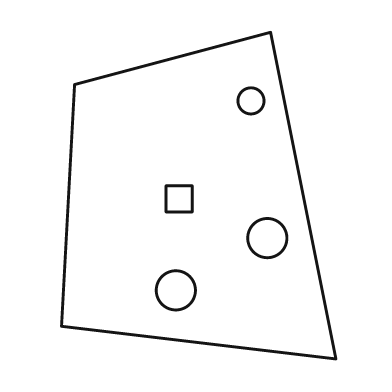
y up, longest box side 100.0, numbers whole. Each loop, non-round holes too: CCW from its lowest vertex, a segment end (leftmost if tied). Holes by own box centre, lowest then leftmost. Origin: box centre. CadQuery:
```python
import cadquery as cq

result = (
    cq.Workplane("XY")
    .moveTo(42.0, -50.0)
    .lineTo(22.0, 50.0)
    .lineTo(-38.0, 34.0)
    .lineTo(-42.0, -40.0)
    .close()
    .moveTo(-7.0, -29.0)
    .circle(6.0)
    .moveTo(21.0, -13.0)
    .circle(6.0)
    .moveTo(-10.0, -5.0)
    .lineTo(-2.0, -5.0)
    .lineTo(-2.0, 3.0)
    .lineTo(-10.0, 3.0)
    .close()
    .moveTo(16.0, 29.0)
    .circle(4.0)
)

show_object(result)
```